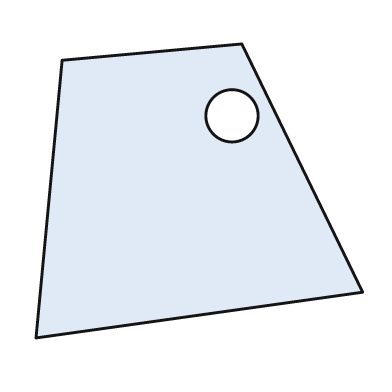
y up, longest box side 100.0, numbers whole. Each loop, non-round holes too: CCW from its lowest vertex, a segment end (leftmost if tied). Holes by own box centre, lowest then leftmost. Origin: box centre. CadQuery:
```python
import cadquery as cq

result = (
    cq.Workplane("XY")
    .moveTo(-50.0, -45.0)
    .lineTo(50.0, -31.0)
    .lineTo(13.0, 45.0)
    .lineTo(-42.0, 40.0)
    .close()
    .moveTo(10.0, 23.0)
    .circle(8.0)
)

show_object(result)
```